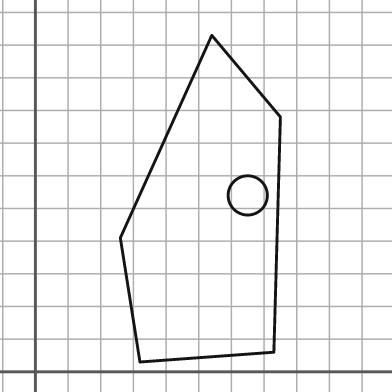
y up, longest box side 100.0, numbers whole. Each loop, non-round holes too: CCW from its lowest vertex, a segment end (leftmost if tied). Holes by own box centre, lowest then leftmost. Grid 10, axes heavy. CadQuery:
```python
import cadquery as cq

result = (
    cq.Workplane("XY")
    .moveTo(32.0, 3.0)
    .lineTo(73.0, 6.0)
    .lineTo(75.0, 78.0)
    .lineTo(54.0, 103.0)
    .lineTo(26.0, 41.0)
    .close()
    .moveTo(65.0, 54.0)
    .circle(6.0)
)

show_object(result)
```